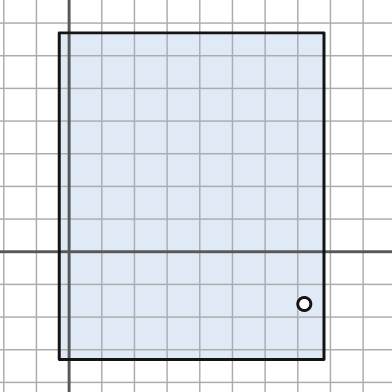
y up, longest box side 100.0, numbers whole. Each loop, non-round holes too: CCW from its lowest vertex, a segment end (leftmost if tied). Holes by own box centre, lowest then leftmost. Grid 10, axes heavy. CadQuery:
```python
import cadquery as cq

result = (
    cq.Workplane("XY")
    .moveTo(-3.0, -33.0)
    .lineTo(78.0, -33.0)
    .lineTo(78.0, 67.0)
    .lineTo(-3.0, 67.0)
    .close()
    .moveTo(72.0, -16.0)
    .circle(2.0)
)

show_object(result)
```